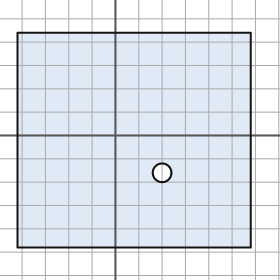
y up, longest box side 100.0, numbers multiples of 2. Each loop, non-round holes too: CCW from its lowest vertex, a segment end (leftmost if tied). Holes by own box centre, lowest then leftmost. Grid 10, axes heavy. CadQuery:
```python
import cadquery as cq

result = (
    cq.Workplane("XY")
    .moveTo(-42.0, -48.0)
    .lineTo(58.0, -48.0)
    .lineTo(58.0, 44.0)
    .lineTo(-42.0, 44.0)
    .close()
    .moveTo(20.0, -16.0)
    .circle(4.0)
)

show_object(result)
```